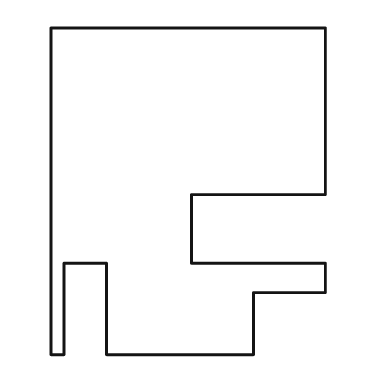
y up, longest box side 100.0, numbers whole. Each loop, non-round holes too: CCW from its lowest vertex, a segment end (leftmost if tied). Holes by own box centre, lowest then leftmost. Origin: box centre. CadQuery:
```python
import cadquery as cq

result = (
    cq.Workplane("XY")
    .moveTo(-42.0, -50.0)
    .lineTo(-38.0, -50.0)
    .lineTo(-38.0, -22.0)
    .lineTo(-25.0, -22.0)
    .lineTo(-25.0, -50.0)
    .lineTo(20.0, -50.0)
    .lineTo(20.0, -31.0)
    .lineTo(42.0, -31.0)
    .lineTo(42.0, -22.0)
    .lineTo(1.0, -22.0)
    .lineTo(1.0, -1.0)
    .lineTo(42.0, -1.0)
    .lineTo(42.0, 50.0)
    .lineTo(-42.0, 50.0)
    .close()
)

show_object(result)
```